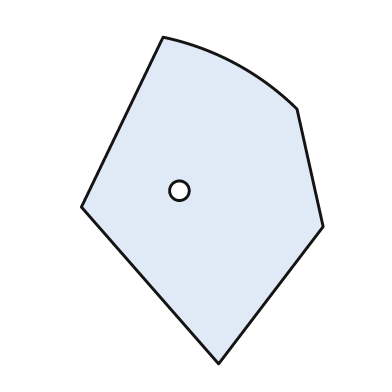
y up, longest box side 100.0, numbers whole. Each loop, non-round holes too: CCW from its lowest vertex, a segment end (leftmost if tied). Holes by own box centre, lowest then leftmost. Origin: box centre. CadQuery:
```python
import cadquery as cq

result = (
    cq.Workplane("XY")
    .moveTo(5.0, -50.0)
    .lineTo(37.0, -8.0)
    .lineTo(29.0, 28.0)
    .threePointArc((10.0, 42.0), (-12.0, 50.0))
    .lineTo(-37.0, -2.0)
    .close()
    .moveTo(-7.0, 3.0)
    .circle(3.0)
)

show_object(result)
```